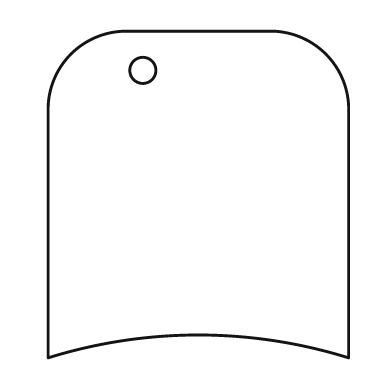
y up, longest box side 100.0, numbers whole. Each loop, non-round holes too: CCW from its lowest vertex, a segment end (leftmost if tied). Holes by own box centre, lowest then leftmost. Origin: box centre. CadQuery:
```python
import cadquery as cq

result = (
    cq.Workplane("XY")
    .moveTo(-46.0, -50.0)
    .threePointArc((0.0, -43.0), (46.0, -50.0))
    .lineTo(46.0, 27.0)
    .threePointArc((39.0, 43.0), (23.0, 50.0))
    .lineTo(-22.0, 50.0)
    .threePointArc((-39.0, 43.0), (-46.0, 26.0))
    .close()
    .moveTo(-17.0, 38.0)
    .circle(4.0)
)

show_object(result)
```